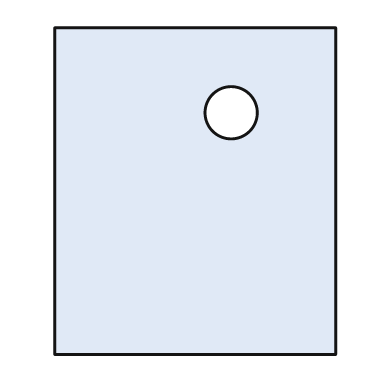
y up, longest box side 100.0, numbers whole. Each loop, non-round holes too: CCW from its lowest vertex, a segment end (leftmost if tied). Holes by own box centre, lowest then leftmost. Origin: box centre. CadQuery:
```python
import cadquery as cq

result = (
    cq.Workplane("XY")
    .moveTo(-43.0, -50.0)
    .lineTo(43.0, -50.0)
    .lineTo(43.0, 50.0)
    .lineTo(-43.0, 50.0)
    .close()
    .moveTo(11.0, 24.0)
    .circle(8.0)
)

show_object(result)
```